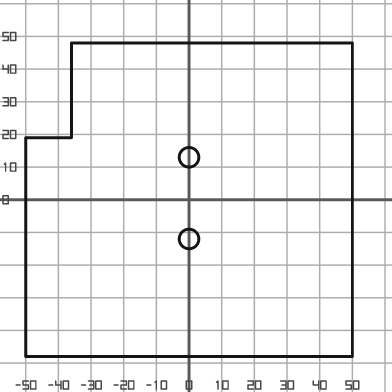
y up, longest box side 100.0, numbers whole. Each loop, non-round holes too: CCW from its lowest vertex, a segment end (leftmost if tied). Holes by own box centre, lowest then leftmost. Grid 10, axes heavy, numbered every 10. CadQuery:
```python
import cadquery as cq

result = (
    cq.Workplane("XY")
    .moveTo(-50.0, -48.0)
    .lineTo(50.0, -48.0)
    .lineTo(50.0, 48.0)
    .lineTo(-36.0, 48.0)
    .lineTo(-36.0, 19.0)
    .lineTo(-50.0, 19.0)
    .close()
    .moveTo(0.0, -12.0)
    .circle(3.0)
    .moveTo(0.0, 13.0)
    .circle(3.0)
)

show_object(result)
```